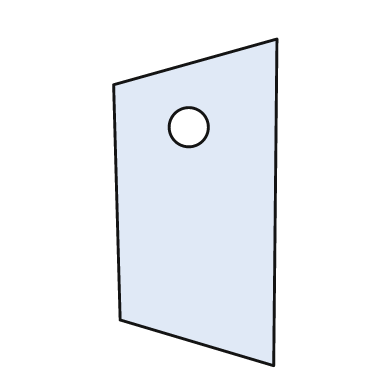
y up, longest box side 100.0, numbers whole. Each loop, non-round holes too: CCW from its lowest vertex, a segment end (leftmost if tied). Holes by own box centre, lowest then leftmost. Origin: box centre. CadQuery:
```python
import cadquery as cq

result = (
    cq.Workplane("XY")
    .moveTo(24.0, -50.0)
    .lineTo(25.0, 50.0)
    .lineTo(-25.0, 36.0)
    .lineTo(-23.0, -36.0)
    .close()
    .moveTo(-2.0, 23.0)
    .circle(6.0)
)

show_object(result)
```